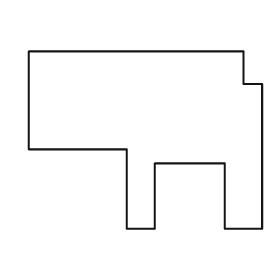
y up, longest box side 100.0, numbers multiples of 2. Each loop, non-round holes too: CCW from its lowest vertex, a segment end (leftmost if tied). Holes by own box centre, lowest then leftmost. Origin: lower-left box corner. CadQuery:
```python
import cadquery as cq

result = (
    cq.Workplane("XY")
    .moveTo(42.0, 0.0)
    .lineTo(54.0, 0.0)
    .lineTo(54.0, 28.0)
    .lineTo(84.0, 28.0)
    .lineTo(84.0, 0.0)
    .lineTo(100.0, 0.0)
    .lineTo(100.0, 62.0)
    .lineTo(92.0, 62.0)
    .lineTo(92.0, 76.0)
    .lineTo(0.0, 76.0)
    .lineTo(0.0, 34.0)
    .lineTo(42.0, 34.0)
    .close()
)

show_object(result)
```